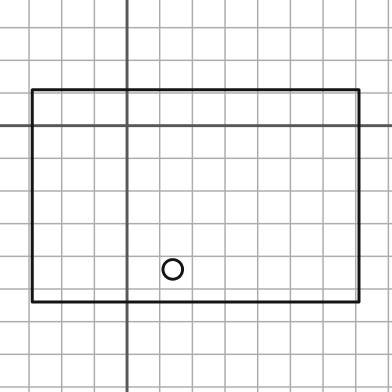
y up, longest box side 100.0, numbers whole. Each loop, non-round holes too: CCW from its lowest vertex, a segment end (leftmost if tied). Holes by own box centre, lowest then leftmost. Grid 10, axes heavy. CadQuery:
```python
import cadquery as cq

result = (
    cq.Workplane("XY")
    .moveTo(-29.0, -54.0)
    .lineTo(71.0, -54.0)
    .lineTo(71.0, 11.0)
    .lineTo(-29.0, 11.0)
    .close()
    .moveTo(14.0, -44.0)
    .circle(3.0)
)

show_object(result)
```